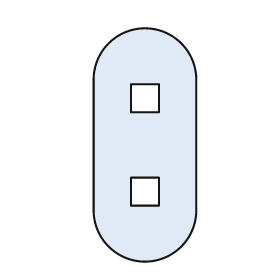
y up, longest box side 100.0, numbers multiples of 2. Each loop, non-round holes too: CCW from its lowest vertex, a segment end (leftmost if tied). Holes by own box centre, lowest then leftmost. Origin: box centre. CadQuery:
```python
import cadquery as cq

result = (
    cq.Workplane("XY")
    .moveTo(-22.0, -28.0)
    .threePointArc((0.0, -50.0), (22.0, -28.0))
    .lineTo(22.0, 28.0)
    .threePointArc((0.0, 50.0), (-22.0, 28.0))
    .close()
    .moveTo(-6.0, -26.0)
    .lineTo(6.0, -26.0)
    .lineTo(6.0, -14.0)
    .lineTo(-6.0, -14.0)
    .close()
    .moveTo(-6.0, 14.0)
    .lineTo(6.0, 14.0)
    .lineTo(6.0, 26.0)
    .lineTo(-6.0, 26.0)
    .close()
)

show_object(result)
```